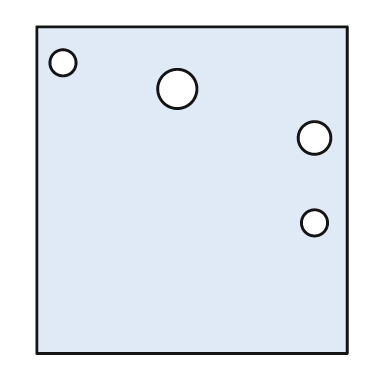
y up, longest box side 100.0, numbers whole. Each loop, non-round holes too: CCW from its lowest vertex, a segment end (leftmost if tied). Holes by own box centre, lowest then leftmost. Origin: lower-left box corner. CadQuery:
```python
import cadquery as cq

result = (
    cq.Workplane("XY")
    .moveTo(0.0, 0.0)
    .lineTo(95.0, 0.0)
    .lineTo(95.0, 100.0)
    .lineTo(0.0, 100.0)
    .close()
    .moveTo(85.0, 40.0)
    .circle(4.0)
    .moveTo(85.0, 66.0)
    .circle(5.0)
    .moveTo(43.0, 81.0)
    .circle(6.0)
    .moveTo(8.0, 89.0)
    .circle(4.0)
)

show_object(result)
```